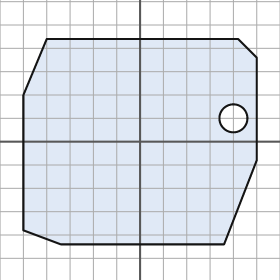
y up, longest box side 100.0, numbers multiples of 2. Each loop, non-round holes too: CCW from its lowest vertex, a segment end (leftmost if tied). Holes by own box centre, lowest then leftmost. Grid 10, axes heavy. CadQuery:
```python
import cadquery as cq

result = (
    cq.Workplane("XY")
    .moveTo(-34.0, -44.0)
    .lineTo(36.0, -44.0)
    .lineTo(50.0, -8.0)
    .lineTo(50.0, 36.0)
    .lineTo(42.0, 44.0)
    .lineTo(-40.0, 44.0)
    .lineTo(-50.0, 20.0)
    .lineTo(-50.0, -38.0)
    .close()
    .moveTo(40.0, 10.0)
    .circle(6.0)
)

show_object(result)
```